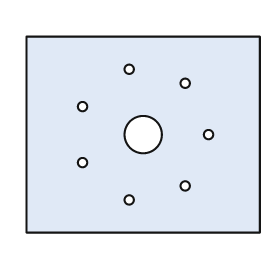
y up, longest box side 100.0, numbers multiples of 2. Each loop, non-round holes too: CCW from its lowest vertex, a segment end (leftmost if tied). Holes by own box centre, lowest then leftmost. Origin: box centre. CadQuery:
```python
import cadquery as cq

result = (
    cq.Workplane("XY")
    .moveTo(-50.0, -42.0)
    .lineTo(50.0, -42.0)
    .lineTo(50.0, 42.0)
    .lineTo(-50.0, 42.0)
    .close()
    .moveTo(-6.0, -28.0)
    .circle(2.0)
    .moveTo(18.0, -22.0)
    .circle(2.0)
    .moveTo(-26.0, -12.0)
    .circle(2.0)
    .moveTo(0.0, 0.0)
    .circle(8.0)
    .moveTo(28.0, 0.0)
    .circle(2.0)
    .moveTo(-26.0, 12.0)
    .circle(2.0)
    .moveTo(18.0, 22.0)
    .circle(2.0)
    .moveTo(-6.0, 28.0)
    .circle(2.0)
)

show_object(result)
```